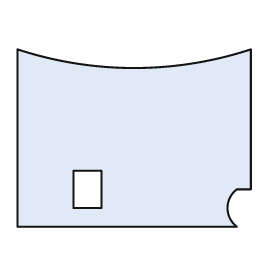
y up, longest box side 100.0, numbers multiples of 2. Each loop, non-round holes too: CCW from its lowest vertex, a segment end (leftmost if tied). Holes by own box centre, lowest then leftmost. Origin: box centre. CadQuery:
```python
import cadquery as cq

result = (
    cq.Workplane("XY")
    .moveTo(-50.0, -38.0)
    .lineTo(44.0, -38.0)
    .threePointArc((40.0, -30.0), (44.0, -22.0))
    .lineTo(50.0, -22.0)
    .lineTo(50.0, 38.0)
    .threePointArc((0.0, 30.0), (-50.0, 38.0))
    .close()
    .moveTo(-26.0, -30.0)
    .lineTo(-14.0, -30.0)
    .lineTo(-14.0, -14.0)
    .lineTo(-26.0, -14.0)
    .close()
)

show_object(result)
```